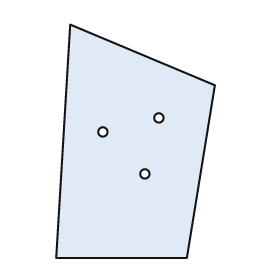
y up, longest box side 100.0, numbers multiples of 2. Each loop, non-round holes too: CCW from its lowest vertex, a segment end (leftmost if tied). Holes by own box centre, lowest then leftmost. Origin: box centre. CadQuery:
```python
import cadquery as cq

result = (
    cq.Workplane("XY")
    .moveTo(-34.0, -50.0)
    .lineTo(22.0, -50.0)
    .lineTo(34.0, 24.0)
    .lineTo(-28.0, 50.0)
    .close()
    .moveTo(4.0, -14.0)
    .circle(2.0)
    .moveTo(-14.0, 4.0)
    .circle(2.0)
    .moveTo(10.0, 10.0)
    .circle(2.0)
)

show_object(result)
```